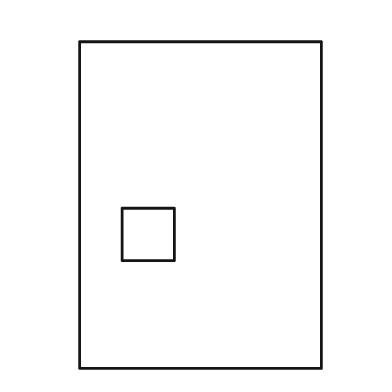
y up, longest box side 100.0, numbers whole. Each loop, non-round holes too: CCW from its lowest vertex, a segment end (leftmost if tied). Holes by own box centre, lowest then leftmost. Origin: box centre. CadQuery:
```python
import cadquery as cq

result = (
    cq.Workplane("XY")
    .moveTo(-37.0, -50.0)
    .lineTo(37.0, -50.0)
    .lineTo(37.0, 50.0)
    .lineTo(-37.0, 50.0)
    .close()
    .moveTo(-24.0, -17.0)
    .lineTo(-8.0, -17.0)
    .lineTo(-8.0, -1.0)
    .lineTo(-24.0, -1.0)
    .close()
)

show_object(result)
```